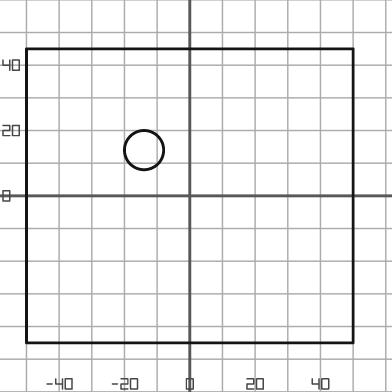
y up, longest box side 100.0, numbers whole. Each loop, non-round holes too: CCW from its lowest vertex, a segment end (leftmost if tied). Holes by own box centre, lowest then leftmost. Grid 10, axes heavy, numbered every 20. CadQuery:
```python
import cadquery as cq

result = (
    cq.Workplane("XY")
    .moveTo(-50.0, -45.0)
    .lineTo(50.0, -45.0)
    .lineTo(50.0, 45.0)
    .lineTo(-50.0, 45.0)
    .close()
    .moveTo(-14.0, 14.0)
    .circle(6.0)
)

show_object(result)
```